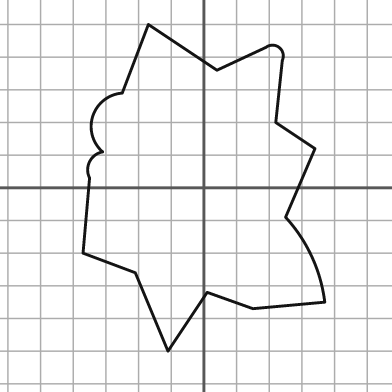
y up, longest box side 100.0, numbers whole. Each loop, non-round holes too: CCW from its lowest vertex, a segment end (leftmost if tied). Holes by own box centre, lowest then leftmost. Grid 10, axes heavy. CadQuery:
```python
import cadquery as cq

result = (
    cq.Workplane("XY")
    .moveTo(-11.0, -50.0)
    .lineTo(1.0, -32.0)
    .lineTo(15.0, -37.0)
    .lineTo(37.0, -35.0)
    .threePointArc((33.0, -21.0), (25.0, -9.0))
    .lineTo(34.0, 12.0)
    .lineTo(22.0, 20.0)
    .lineTo(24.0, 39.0)
    .threePointArc((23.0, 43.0), (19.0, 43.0))
    .lineTo(4.0, 36.0)
    .lineTo(-17.0, 50.0)
    .lineTo(-25.0, 29.0)
    .threePointArc((-34.0, 22.0), (-31.0, 11.0))
    .threePointArc((-35.0, 8.0), (-35.0, 3.0))
    .lineTo(-37.0, -20.0)
    .lineTo(-21.0, -26.0)
    .close()
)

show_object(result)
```